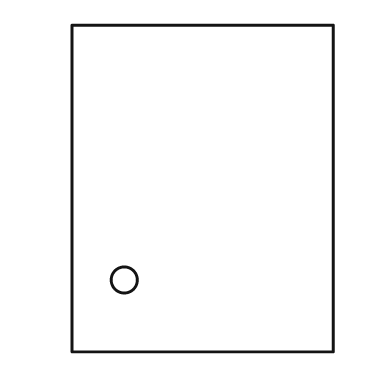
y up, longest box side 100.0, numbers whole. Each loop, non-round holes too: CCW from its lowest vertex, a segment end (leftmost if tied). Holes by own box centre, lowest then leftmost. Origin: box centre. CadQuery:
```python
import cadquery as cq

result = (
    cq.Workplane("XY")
    .moveTo(-40.0, -50.0)
    .lineTo(40.0, -50.0)
    .lineTo(40.0, 50.0)
    .lineTo(-40.0, 50.0)
    .close()
    .moveTo(-24.0, -28.0)
    .circle(4.0)
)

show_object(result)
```